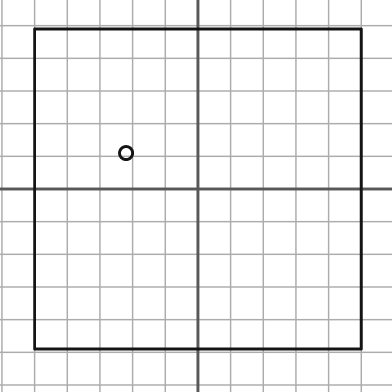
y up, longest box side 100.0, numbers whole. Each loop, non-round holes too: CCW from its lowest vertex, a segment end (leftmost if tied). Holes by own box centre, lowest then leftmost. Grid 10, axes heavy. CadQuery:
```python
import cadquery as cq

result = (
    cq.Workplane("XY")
    .moveTo(-50.0, -49.0)
    .lineTo(50.0, -49.0)
    .lineTo(50.0, 49.0)
    .lineTo(-50.0, 49.0)
    .close()
    .moveTo(-22.0, 11.0)
    .circle(2.0)
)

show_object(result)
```